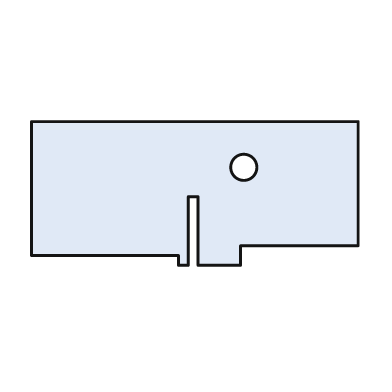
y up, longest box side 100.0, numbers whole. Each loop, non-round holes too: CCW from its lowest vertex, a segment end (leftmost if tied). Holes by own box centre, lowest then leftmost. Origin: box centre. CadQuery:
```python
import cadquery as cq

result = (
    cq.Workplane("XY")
    .moveTo(-5.0, -22.0)
    .lineTo(-2.0, -22.0)
    .lineTo(-2.0, -1.0)
    .lineTo(1.0, -1.0)
    .lineTo(1.0, -22.0)
    .lineTo(14.0, -22.0)
    .lineTo(14.0, -16.0)
    .lineTo(50.0, -16.0)
    .lineTo(50.0, 22.0)
    .lineTo(-50.0, 22.0)
    .lineTo(-50.0, -19.0)
    .lineTo(-5.0, -19.0)
    .close()
    .moveTo(15.0, 8.0)
    .circle(4.0)
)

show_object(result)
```